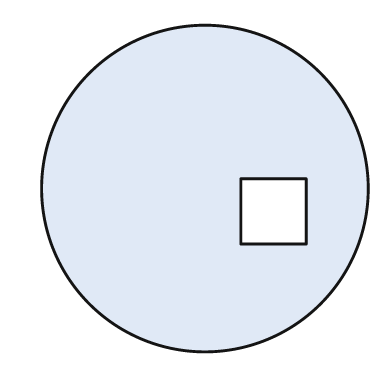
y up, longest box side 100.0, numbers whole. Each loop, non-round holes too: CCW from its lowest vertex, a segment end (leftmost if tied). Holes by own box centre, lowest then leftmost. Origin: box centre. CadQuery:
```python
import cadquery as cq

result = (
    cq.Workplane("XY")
    .moveTo(0.0, 0.0)
    .circle(50.0)
    .moveTo(11.0, -17.0)
    .lineTo(31.0, -17.0)
    .lineTo(31.0, 3.0)
    .lineTo(11.0, 3.0)
    .close()
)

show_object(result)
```